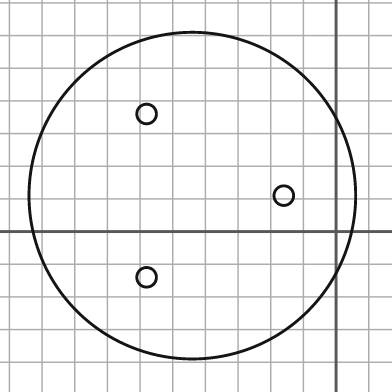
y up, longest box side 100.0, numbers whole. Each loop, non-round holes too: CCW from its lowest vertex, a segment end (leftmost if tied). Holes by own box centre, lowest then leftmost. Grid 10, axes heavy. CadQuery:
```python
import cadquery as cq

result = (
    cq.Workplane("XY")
    .moveTo(-44.0, 11.0)
    .circle(50.0)
    .moveTo(-58.0, -14.0)
    .circle(3.0)
    .moveTo(-16.0, 11.0)
    .circle(3.0)
    .moveTo(-58.0, 36.0)
    .circle(3.0)
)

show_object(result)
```